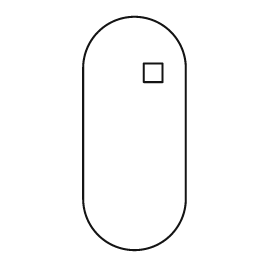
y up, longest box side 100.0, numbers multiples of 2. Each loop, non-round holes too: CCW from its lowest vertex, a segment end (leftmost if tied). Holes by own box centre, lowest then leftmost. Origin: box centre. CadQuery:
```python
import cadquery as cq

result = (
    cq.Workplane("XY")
    .moveTo(-22.0, -28.0)
    .threePointArc((0.0, -50.0), (22.0, -28.0))
    .lineTo(22.0, 28.0)
    .threePointArc((0.0, 50.0), (-22.0, 28.0))
    .close()
    .moveTo(4.0, 22.0)
    .lineTo(12.0, 22.0)
    .lineTo(12.0, 30.0)
    .lineTo(4.0, 30.0)
    .close()
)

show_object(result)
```